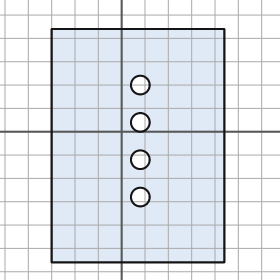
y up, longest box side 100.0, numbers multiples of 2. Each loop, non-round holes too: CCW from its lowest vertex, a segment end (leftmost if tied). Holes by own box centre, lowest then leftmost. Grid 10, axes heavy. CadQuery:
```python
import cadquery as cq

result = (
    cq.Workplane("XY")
    .moveTo(-30.0, -56.0)
    .lineTo(44.0, -56.0)
    .lineTo(44.0, 44.0)
    .lineTo(-30.0, 44.0)
    .close()
    .moveTo(8.0, -28.0)
    .circle(4.0)
    .moveTo(8.0, -12.0)
    .circle(4.0)
    .moveTo(8.0, 4.0)
    .circle(4.0)
    .moveTo(8.0, 20.0)
    .circle(4.0)
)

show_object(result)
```